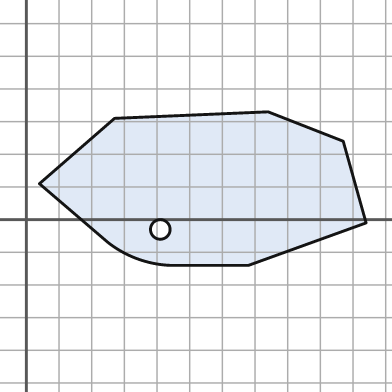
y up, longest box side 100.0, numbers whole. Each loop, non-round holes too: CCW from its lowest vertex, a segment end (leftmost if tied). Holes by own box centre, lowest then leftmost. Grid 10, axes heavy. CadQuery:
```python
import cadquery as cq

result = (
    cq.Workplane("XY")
    .moveTo(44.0, -14.0)
    .lineTo(68.0, -14.0)
    .lineTo(104.0, -1.0)
    .lineTo(97.0, 24.0)
    .lineTo(74.0, 33.0)
    .lineTo(27.0, 31.0)
    .lineTo(4.0, 11.0)
    .lineTo(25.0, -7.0)
    .threePointArc((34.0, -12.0), (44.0, -14.0))
    .close()
    .moveTo(41.0, -3.0)
    .circle(3.0)
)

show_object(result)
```